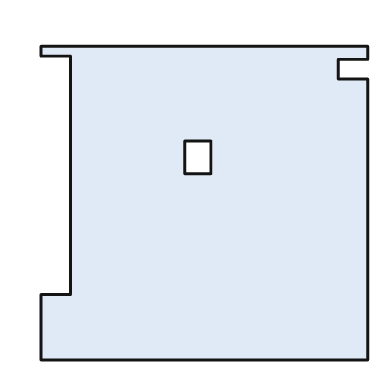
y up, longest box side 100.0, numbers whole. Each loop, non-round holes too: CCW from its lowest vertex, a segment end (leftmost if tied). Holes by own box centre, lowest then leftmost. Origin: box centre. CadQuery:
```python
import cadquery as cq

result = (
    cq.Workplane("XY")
    .moveTo(-50.0, -48.0)
    .lineTo(50.0, -48.0)
    .lineTo(50.0, 38.0)
    .lineTo(41.0, 38.0)
    .lineTo(41.0, 44.0)
    .lineTo(50.0, 44.0)
    .lineTo(50.0, 48.0)
    .lineTo(-50.0, 48.0)
    .lineTo(-50.0, 45.0)
    .lineTo(-41.0, 45.0)
    .lineTo(-41.0, -28.0)
    .lineTo(-50.0, -28.0)
    .close()
    .moveTo(-6.0, 9.0)
    .lineTo(2.0, 9.0)
    .lineTo(2.0, 19.0)
    .lineTo(-6.0, 19.0)
    .close()
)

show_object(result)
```